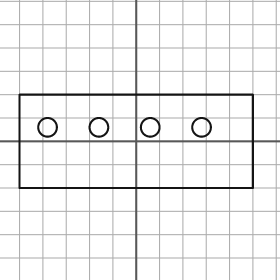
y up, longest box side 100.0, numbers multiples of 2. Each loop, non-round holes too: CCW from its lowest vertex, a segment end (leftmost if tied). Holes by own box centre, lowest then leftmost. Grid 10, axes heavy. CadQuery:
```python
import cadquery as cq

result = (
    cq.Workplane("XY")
    .moveTo(-50.0, -20.0)
    .lineTo(50.0, -20.0)
    .lineTo(50.0, 20.0)
    .lineTo(-50.0, 20.0)
    .close()
    .moveTo(-38.0, 6.0)
    .circle(4.0)
    .moveTo(-16.0, 6.0)
    .circle(4.0)
    .moveTo(6.0, 6.0)
    .circle(4.0)
    .moveTo(28.0, 6.0)
    .circle(4.0)
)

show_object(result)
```